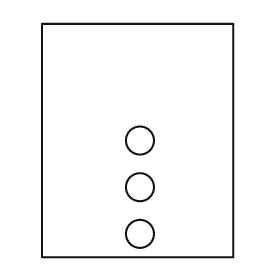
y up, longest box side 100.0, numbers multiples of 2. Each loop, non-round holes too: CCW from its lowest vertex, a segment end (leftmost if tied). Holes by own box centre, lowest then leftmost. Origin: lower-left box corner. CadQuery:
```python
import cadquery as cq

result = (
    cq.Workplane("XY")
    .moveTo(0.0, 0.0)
    .lineTo(82.0, 0.0)
    .lineTo(82.0, 100.0)
    .lineTo(0.0, 100.0)
    .close()
    .moveTo(42.0, 10.0)
    .circle(6.0)
    .moveTo(42.0, 30.0)
    .circle(6.0)
    .moveTo(42.0, 50.0)
    .circle(6.0)
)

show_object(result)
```